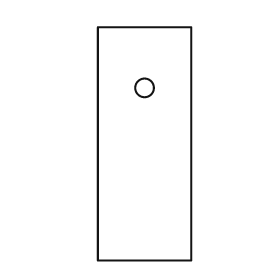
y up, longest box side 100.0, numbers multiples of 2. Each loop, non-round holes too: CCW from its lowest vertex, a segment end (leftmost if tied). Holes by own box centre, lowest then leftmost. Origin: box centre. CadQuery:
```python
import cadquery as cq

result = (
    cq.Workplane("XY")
    .moveTo(-20.0, -50.0)
    .lineTo(20.0, -50.0)
    .lineTo(20.0, 50.0)
    .lineTo(-20.0, 50.0)
    .close()
    .moveTo(0.0, 24.0)
    .circle(4.0)
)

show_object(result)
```